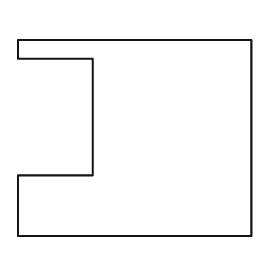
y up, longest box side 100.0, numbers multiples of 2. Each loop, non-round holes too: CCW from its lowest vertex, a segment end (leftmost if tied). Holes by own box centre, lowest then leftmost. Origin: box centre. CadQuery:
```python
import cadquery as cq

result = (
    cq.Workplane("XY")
    .moveTo(-50.0, -42.0)
    .lineTo(50.0, -42.0)
    .lineTo(50.0, 42.0)
    .lineTo(-50.0, 42.0)
    .lineTo(-50.0, 34.0)
    .lineTo(-18.0, 34.0)
    .lineTo(-18.0, -16.0)
    .lineTo(-50.0, -16.0)
    .close()
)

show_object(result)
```